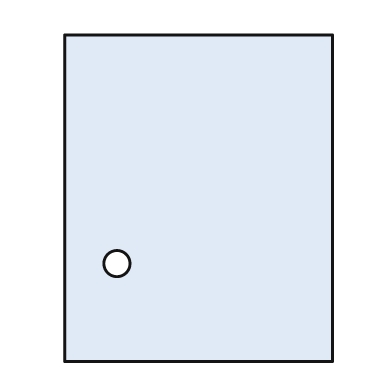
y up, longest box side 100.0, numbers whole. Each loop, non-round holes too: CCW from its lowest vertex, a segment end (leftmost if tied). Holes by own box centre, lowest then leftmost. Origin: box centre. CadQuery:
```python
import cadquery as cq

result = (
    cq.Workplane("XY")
    .moveTo(-41.0, -50.0)
    .lineTo(41.0, -50.0)
    .lineTo(41.0, 50.0)
    .lineTo(-41.0, 50.0)
    .close()
    .moveTo(-25.0, -20.0)
    .circle(4.0)
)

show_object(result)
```